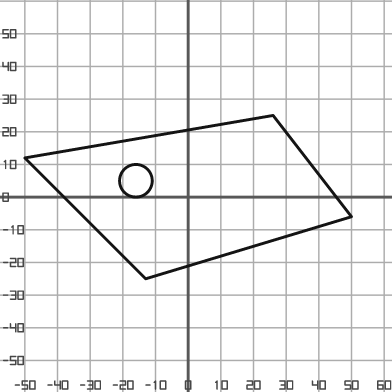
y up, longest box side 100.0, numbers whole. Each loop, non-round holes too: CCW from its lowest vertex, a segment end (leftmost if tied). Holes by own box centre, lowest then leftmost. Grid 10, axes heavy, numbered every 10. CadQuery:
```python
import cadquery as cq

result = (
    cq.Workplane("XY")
    .moveTo(-13.0, -25.0)
    .lineTo(50.0, -6.0)
    .lineTo(26.0, 25.0)
    .lineTo(-50.0, 12.0)
    .close()
    .moveTo(-16.0, 5.0)
    .circle(5.0)
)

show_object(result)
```